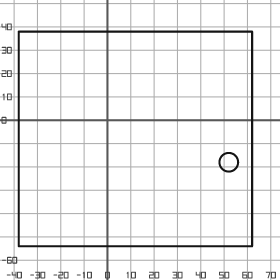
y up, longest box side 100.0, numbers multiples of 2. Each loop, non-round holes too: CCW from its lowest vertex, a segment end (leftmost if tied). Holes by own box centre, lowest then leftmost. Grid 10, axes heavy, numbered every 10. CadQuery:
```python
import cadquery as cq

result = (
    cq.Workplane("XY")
    .moveTo(-38.0, -54.0)
    .lineTo(62.0, -54.0)
    .lineTo(62.0, 38.0)
    .lineTo(-38.0, 38.0)
    .close()
    .moveTo(52.0, -18.0)
    .circle(4.0)
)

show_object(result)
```